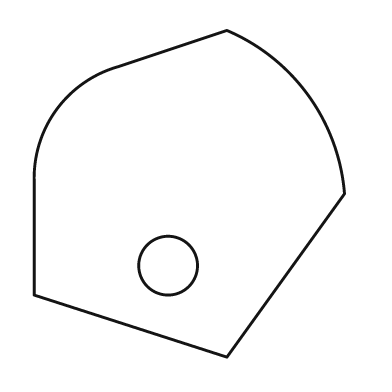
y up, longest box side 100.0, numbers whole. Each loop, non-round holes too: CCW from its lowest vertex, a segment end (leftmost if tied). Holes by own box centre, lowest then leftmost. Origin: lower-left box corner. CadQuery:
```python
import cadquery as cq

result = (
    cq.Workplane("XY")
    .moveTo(59.0, 0.0)
    .lineTo(95.0, 50.0)
    .threePointArc((84.0, 80.0), (59.0, 100.0))
    .lineTo(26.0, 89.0)
    .threePointArc((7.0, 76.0), (0.0, 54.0))
    .lineTo(0.0, 19.0)
    .close()
    .moveTo(41.0, 28.0)
    .circle(9.0)
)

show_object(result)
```